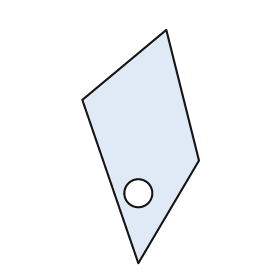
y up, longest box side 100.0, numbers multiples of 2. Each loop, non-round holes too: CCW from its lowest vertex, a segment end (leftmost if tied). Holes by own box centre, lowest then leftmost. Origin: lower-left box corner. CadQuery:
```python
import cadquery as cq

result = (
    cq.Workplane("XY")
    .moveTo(24.0, 0.0)
    .lineTo(50.0, 44.0)
    .lineTo(36.0, 100.0)
    .lineTo(0.0, 70.0)
    .close()
    .moveTo(24.0, 30.0)
    .circle(6.0)
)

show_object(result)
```